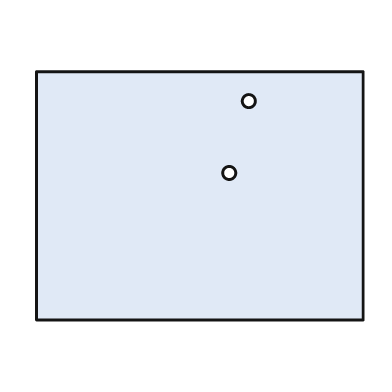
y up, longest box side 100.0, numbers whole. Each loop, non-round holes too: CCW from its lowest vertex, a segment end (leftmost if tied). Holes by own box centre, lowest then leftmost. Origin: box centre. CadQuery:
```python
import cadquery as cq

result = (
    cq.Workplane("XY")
    .moveTo(-50.0, -38.0)
    .lineTo(50.0, -38.0)
    .lineTo(50.0, 38.0)
    .lineTo(-50.0, 38.0)
    .close()
    .moveTo(9.0, 7.0)
    .circle(2.0)
    .moveTo(15.0, 29.0)
    .circle(2.0)
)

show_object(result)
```